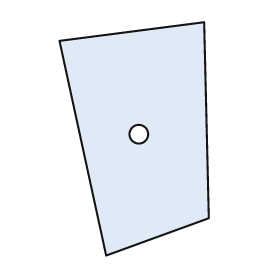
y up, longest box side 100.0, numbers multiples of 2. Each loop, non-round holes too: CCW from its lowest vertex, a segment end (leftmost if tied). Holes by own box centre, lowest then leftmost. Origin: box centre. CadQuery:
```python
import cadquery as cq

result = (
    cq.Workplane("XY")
    .moveTo(-12.0, -50.0)
    .lineTo(32.0, -34.0)
    .lineTo(30.0, 50.0)
    .lineTo(-32.0, 42.0)
    .close()
    .moveTo(2.0, 2.0)
    .circle(4.0)
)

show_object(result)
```